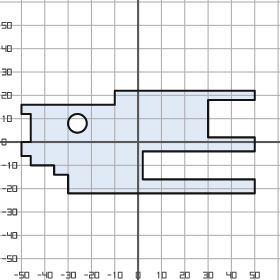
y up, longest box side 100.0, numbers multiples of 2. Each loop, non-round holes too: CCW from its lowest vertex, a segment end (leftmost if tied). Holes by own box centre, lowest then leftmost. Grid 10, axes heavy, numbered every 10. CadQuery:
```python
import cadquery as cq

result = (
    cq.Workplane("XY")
    .moveTo(-30.0, -22.0)
    .lineTo(50.0, -22.0)
    .lineTo(50.0, -16.0)
    .lineTo(2.0, -16.0)
    .lineTo(2.0, -4.0)
    .lineTo(50.0, -4.0)
    .lineTo(50.0, 2.0)
    .lineTo(30.0, 2.0)
    .lineTo(30.0, 18.0)
    .lineTo(50.0, 18.0)
    .lineTo(50.0, 22.0)
    .lineTo(-10.0, 22.0)
    .lineTo(-10.0, 16.0)
    .lineTo(-50.0, 16.0)
    .lineTo(-50.0, 12.0)
    .lineTo(-46.0, 12.0)
    .lineTo(-46.0, 0.0)
    .lineTo(-50.0, 0.0)
    .lineTo(-50.0, -6.0)
    .lineTo(-46.0, -6.0)
    .lineTo(-46.0, -10.0)
    .lineTo(-36.0, -10.0)
    .lineTo(-36.0, -14.0)
    .lineTo(-30.0, -14.0)
    .close()
    .moveTo(-26.0, 8.0)
    .circle(4.0)
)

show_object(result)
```